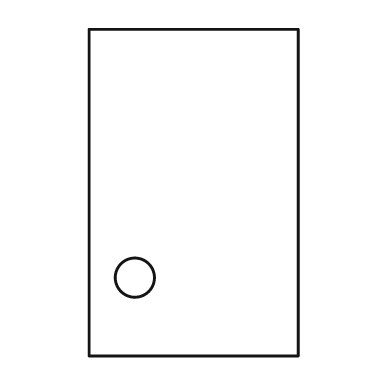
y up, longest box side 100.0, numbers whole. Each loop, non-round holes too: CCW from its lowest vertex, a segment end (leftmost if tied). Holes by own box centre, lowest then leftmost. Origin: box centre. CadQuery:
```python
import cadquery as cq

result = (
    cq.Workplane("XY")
    .moveTo(-32.0, -50.0)
    .lineTo(32.0, -50.0)
    .lineTo(32.0, 50.0)
    .lineTo(-32.0, 50.0)
    .close()
    .moveTo(-18.0, -26.0)
    .circle(6.0)
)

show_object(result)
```